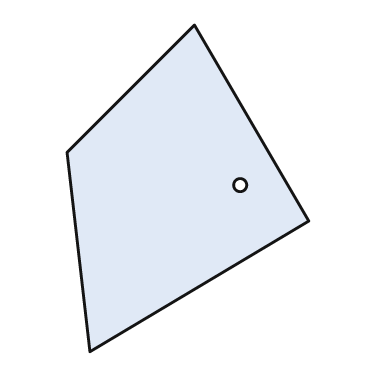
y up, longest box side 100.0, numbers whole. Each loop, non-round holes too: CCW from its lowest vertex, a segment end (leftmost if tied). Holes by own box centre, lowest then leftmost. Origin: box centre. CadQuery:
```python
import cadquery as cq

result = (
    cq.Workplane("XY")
    .moveTo(-30.0, -50.0)
    .lineTo(37.0, -10.0)
    .lineTo(2.0, 50.0)
    .lineTo(-37.0, 11.0)
    .close()
    .moveTo(16.0, 1.0)
    .circle(2.0)
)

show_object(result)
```